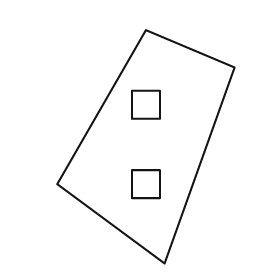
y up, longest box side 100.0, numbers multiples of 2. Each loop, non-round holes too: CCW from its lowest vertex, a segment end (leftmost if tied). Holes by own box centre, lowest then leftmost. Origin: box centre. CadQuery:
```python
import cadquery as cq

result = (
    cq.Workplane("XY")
    .moveTo(8.0, -50.0)
    .lineTo(38.0, 34.0)
    .lineTo(0.0, 50.0)
    .lineTo(-38.0, -16.0)
    .close()
    .moveTo(-6.0, -22.0)
    .lineTo(6.0, -22.0)
    .lineTo(6.0, -10.0)
    .lineTo(-6.0, -10.0)
    .close()
    .moveTo(-6.0, 12.0)
    .lineTo(6.0, 12.0)
    .lineTo(6.0, 24.0)
    .lineTo(-6.0, 24.0)
    .close()
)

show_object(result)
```